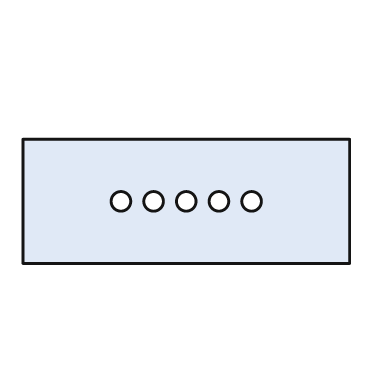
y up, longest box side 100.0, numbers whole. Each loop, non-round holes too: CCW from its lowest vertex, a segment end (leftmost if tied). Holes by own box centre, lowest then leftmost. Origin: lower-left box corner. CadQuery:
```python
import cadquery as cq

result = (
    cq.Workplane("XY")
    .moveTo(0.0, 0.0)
    .lineTo(100.0, 0.0)
    .lineTo(100.0, 38.0)
    .lineTo(0.0, 38.0)
    .close()
    .moveTo(30.0, 19.0)
    .circle(3.0)
    .moveTo(40.0, 19.0)
    .circle(3.0)
    .moveTo(50.0, 19.0)
    .circle(3.0)
    .moveTo(60.0, 19.0)
    .circle(3.0)
    .moveTo(70.0, 19.0)
    .circle(3.0)
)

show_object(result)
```